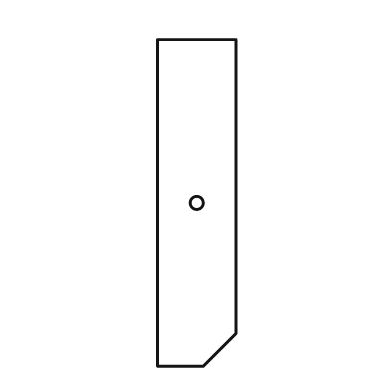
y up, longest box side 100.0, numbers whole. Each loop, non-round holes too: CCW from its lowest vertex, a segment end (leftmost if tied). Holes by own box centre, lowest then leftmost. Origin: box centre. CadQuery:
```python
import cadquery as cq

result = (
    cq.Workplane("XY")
    .moveTo(-12.0, -50.0)
    .lineTo(2.0, -50.0)
    .lineTo(12.0, -40.0)
    .lineTo(12.0, 50.0)
    .lineTo(-12.0, 50.0)
    .close()
    .moveTo(0.0, 0.0)
    .circle(2.0)
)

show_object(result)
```